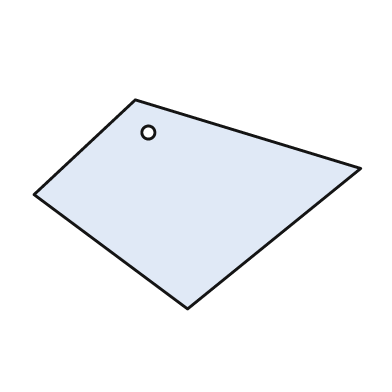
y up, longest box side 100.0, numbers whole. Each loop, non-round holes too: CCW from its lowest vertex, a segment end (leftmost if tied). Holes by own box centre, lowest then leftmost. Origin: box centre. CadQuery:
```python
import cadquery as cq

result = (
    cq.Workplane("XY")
    .moveTo(-3.0, -32.0)
    .lineTo(50.0, 11.0)
    .lineTo(-19.0, 32.0)
    .lineTo(-50.0, 3.0)
    .close()
    .moveTo(-15.0, 22.0)
    .circle(2.0)
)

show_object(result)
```